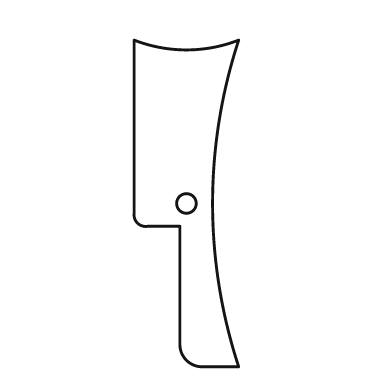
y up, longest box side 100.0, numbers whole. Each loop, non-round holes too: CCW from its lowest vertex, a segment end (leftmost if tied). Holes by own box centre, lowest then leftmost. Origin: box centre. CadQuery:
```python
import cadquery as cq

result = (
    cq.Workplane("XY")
    .moveTo(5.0, -50.0)
    .lineTo(16.0, -50.0)
    .threePointArc((8.0, 0.0), (16.0, 50.0))
    .threePointArc((0.0, 47.0), (-16.0, 50.0))
    .lineTo(-16.0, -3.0)
    .threePointArc((-15.0, -6.0), (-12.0, -7.0))
    .lineTo(-2.0, -7.0)
    .lineTo(-2.0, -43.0)
    .threePointArc((0.0, -48.0), (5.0, -50.0))
    .close()
    .moveTo(0.0, 0.0)
    .circle(3.0)
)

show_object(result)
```